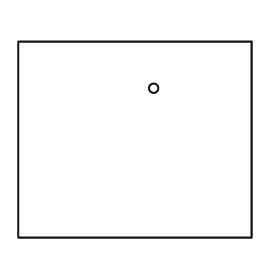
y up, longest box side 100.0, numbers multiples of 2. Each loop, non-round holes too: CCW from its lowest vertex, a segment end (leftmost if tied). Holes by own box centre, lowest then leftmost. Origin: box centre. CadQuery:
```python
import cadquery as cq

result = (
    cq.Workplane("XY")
    .moveTo(-50.0, -42.0)
    .lineTo(50.0, -42.0)
    .lineTo(50.0, 42.0)
    .lineTo(-50.0, 42.0)
    .close()
    .moveTo(8.0, 22.0)
    .circle(2.0)
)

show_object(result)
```